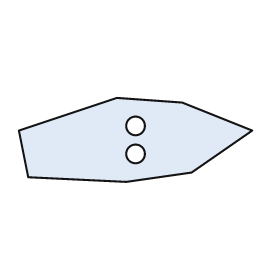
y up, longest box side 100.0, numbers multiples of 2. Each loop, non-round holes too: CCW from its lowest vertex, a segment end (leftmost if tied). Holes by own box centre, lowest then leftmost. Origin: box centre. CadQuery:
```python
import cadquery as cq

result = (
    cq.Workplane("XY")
    .moveTo(-4.0, -18.0)
    .lineTo(24.0, -14.0)
    .lineTo(50.0, 4.0)
    .lineTo(20.0, 16.0)
    .lineTo(-8.0, 18.0)
    .lineTo(-50.0, 4.0)
    .lineTo(-46.0, -16.0)
    .close()
    .moveTo(0.0, -6.0)
    .circle(4.0)
    .moveTo(0.0, 6.0)
    .circle(4.0)
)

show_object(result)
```